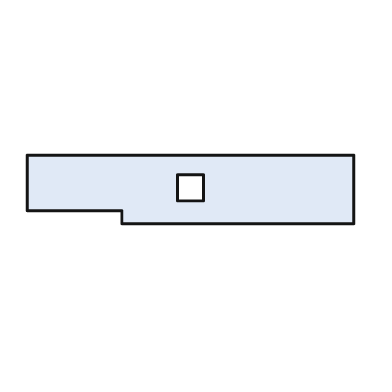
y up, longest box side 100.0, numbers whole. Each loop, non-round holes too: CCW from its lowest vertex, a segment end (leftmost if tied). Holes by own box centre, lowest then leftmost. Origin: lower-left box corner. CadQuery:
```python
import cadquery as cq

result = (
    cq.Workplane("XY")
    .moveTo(29.0, 0.0)
    .lineTo(100.0, 0.0)
    .lineTo(100.0, 21.0)
    .lineTo(0.0, 21.0)
    .lineTo(0.0, 4.0)
    .lineTo(29.0, 4.0)
    .close()
    .moveTo(46.0, 7.0)
    .lineTo(54.0, 7.0)
    .lineTo(54.0, 15.0)
    .lineTo(46.0, 15.0)
    .close()
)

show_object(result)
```